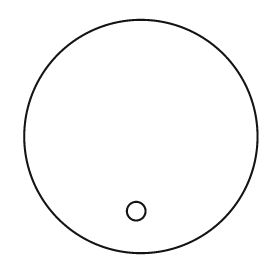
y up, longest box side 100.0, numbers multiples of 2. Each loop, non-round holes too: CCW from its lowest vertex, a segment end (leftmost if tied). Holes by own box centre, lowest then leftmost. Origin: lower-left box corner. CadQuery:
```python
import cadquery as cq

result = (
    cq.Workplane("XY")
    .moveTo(50.0, 50.0)
    .circle(50.0)
    .moveTo(48.0, 18.0)
    .circle(4.0)
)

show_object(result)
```